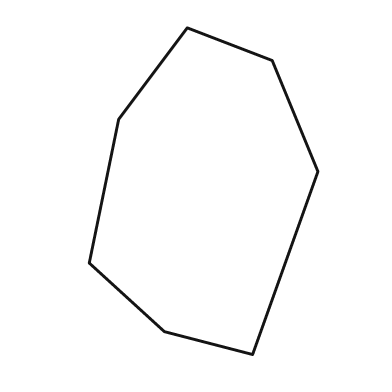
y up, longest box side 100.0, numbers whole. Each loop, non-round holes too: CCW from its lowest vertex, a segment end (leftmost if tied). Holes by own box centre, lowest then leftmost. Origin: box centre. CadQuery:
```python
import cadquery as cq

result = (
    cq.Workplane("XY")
    .moveTo(15.0, -50.0)
    .lineTo(35.0, 6.0)
    .lineTo(21.0, 40.0)
    .lineTo(-5.0, 50.0)
    .lineTo(-26.0, 22.0)
    .lineTo(-35.0, -22.0)
    .lineTo(-12.0, -43.0)
    .close()
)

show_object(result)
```